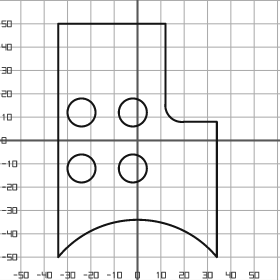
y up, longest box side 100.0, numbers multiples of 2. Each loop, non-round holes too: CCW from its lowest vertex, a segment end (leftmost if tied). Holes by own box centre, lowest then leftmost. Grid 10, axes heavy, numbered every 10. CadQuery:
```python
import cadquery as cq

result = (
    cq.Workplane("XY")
    .moveTo(-34.0, -50.0)
    .threePointArc((0.0, -34.0), (34.0, -50.0))
    .lineTo(34.0, 8.0)
    .lineTo(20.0, 8.0)
    .threePointArc((14.0, 10.0), (12.0, 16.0))
    .lineTo(12.0, 50.0)
    .lineTo(-34.0, 50.0)
    .close()
    .moveTo(-24.0, -12.0)
    .circle(6.0)
    .moveTo(-2.0, -12.0)
    .circle(6.0)
    .moveTo(-24.0, 12.0)
    .circle(6.0)
    .moveTo(-2.0, 12.0)
    .circle(6.0)
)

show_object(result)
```